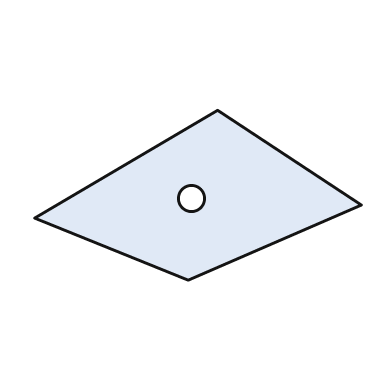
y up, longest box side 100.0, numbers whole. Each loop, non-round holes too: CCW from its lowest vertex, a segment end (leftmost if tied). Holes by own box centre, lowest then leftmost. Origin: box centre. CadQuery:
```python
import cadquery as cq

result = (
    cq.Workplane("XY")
    .moveTo(-3.0, -26.0)
    .lineTo(50.0, -3.0)
    .lineTo(6.0, 26.0)
    .lineTo(-50.0, -7.0)
    .close()
    .moveTo(-2.0, -1.0)
    .circle(4.0)
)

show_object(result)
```